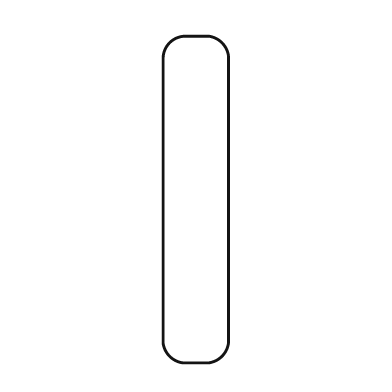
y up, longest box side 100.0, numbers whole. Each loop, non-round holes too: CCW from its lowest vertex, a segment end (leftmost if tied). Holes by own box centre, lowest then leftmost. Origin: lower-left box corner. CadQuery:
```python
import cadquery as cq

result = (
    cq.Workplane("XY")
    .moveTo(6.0, 0.0)
    .lineTo(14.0, 0.0)
    .threePointArc((18.0, 2.0), (20.0, 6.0))
    .lineTo(20.0, 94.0)
    .threePointArc((18.0, 98.0), (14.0, 100.0))
    .lineTo(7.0, 100.0)
    .threePointArc((2.0, 98.0), (0.0, 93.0))
    .lineTo(0.0, 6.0)
    .threePointArc((2.0, 2.0), (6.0, 0.0))
    .close()
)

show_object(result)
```